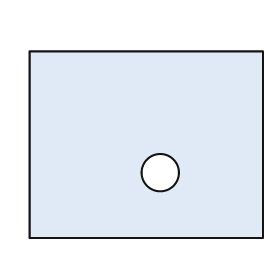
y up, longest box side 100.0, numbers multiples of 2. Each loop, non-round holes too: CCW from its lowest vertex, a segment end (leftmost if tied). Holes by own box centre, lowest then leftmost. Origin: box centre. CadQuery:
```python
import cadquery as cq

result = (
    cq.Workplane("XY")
    .moveTo(-50.0, -40.0)
    .lineTo(50.0, -40.0)
    .lineTo(50.0, 40.0)
    .lineTo(-50.0, 40.0)
    .close()
    .moveTo(6.0, -12.0)
    .circle(8.0)
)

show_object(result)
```